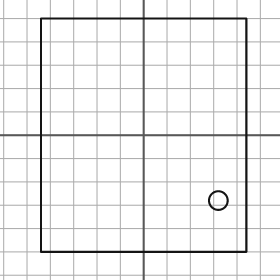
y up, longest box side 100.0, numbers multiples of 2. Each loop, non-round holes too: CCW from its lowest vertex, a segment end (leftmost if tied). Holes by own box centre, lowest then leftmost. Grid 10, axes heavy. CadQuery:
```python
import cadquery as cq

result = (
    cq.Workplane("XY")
    .moveTo(-44.0, -50.0)
    .lineTo(44.0, -50.0)
    .lineTo(44.0, 50.0)
    .lineTo(-44.0, 50.0)
    .close()
    .moveTo(32.0, -28.0)
    .circle(4.0)
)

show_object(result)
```